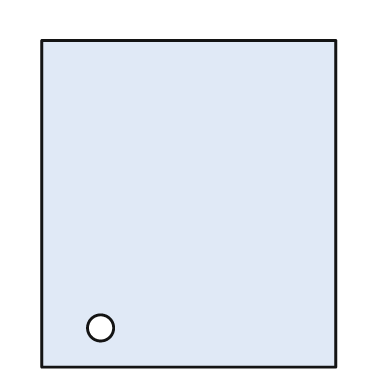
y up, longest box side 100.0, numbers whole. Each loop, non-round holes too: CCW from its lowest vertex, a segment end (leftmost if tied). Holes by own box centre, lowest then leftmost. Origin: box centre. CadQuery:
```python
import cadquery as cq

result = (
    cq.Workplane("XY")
    .moveTo(-45.0, -50.0)
    .lineTo(45.0, -50.0)
    .lineTo(45.0, 50.0)
    .lineTo(-45.0, 50.0)
    .close()
    .moveTo(-27.0, -38.0)
    .circle(4.0)
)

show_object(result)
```